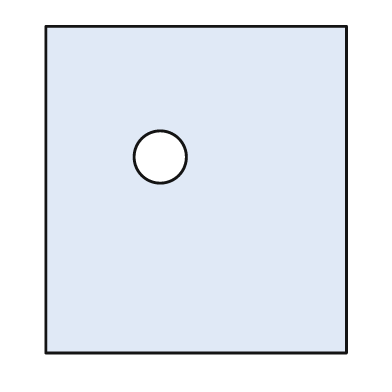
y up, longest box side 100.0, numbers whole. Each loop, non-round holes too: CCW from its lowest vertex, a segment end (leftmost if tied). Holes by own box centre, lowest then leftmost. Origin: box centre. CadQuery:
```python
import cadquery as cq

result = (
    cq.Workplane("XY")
    .moveTo(-46.0, -50.0)
    .lineTo(46.0, -50.0)
    .lineTo(46.0, 50.0)
    .lineTo(-46.0, 50.0)
    .close()
    .moveTo(-11.0, 10.0)
    .circle(8.0)
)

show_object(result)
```